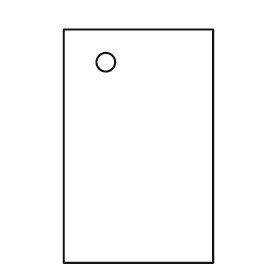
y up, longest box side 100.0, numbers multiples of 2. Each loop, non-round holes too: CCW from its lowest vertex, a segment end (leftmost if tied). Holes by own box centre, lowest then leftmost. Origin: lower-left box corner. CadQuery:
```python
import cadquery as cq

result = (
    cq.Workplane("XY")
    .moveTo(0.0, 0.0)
    .lineTo(64.0, 0.0)
    .lineTo(64.0, 100.0)
    .lineTo(0.0, 100.0)
    .close()
    .moveTo(18.0, 86.0)
    .circle(4.0)
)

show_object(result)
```